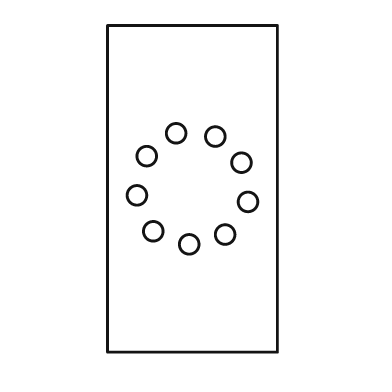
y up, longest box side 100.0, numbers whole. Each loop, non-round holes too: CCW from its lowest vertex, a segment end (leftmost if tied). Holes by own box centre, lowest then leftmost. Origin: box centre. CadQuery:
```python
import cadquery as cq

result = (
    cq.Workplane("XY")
    .moveTo(-26.0, -50.0)
    .lineTo(26.0, -50.0)
    .lineTo(26.0, 50.0)
    .lineTo(-26.0, 50.0)
    .close()
    .moveTo(-1.0, -17.0)
    .circle(3.0)
    .moveTo(10.0, -14.0)
    .circle(3.0)
    .moveTo(-12.0, -13.0)
    .circle(3.0)
    .moveTo(17.0, -4.0)
    .circle(3.0)
    .moveTo(-17.0, -2.0)
    .circle(3.0)
    .moveTo(15.0, 8.0)
    .circle(3.0)
    .moveTo(-14.0, 10.0)
    .circle(3.0)
    .moveTo(7.0, 16.0)
    .circle(3.0)
    .moveTo(-5.0, 17.0)
    .circle(3.0)
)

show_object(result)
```